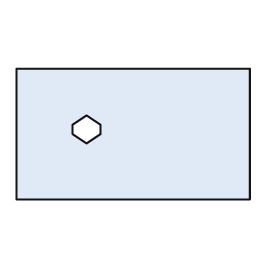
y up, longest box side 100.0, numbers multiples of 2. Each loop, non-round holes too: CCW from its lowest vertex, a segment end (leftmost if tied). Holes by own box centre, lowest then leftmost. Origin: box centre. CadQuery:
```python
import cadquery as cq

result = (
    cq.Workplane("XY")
    .moveTo(-50.0, -28.0)
    .lineTo(50.0, -28.0)
    .lineTo(50.0, 28.0)
    .lineTo(-50.0, 28.0)
    .close()
    .moveTo(-20.0, -4.0)
    .lineTo(-14.0, 0.0)
    .lineTo(-14.0, 4.0)
    .lineTo(-20.0, 8.0)
    .lineTo(-26.0, 4.0)
    .lineTo(-26.0, 0.0)
    .close()
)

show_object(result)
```